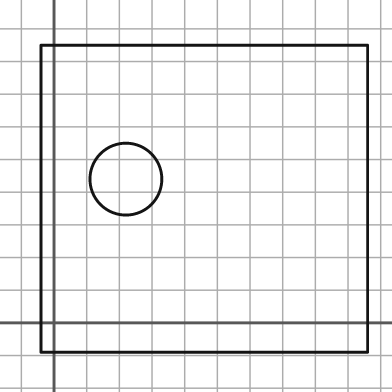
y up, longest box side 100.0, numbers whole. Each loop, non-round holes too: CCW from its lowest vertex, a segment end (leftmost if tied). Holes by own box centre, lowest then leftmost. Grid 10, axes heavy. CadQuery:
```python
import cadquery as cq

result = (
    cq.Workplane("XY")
    .moveTo(-4.0, -9.0)
    .lineTo(96.0, -9.0)
    .lineTo(96.0, 85.0)
    .lineTo(-4.0, 85.0)
    .close()
    .moveTo(22.0, 44.0)
    .circle(11.0)
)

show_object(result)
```